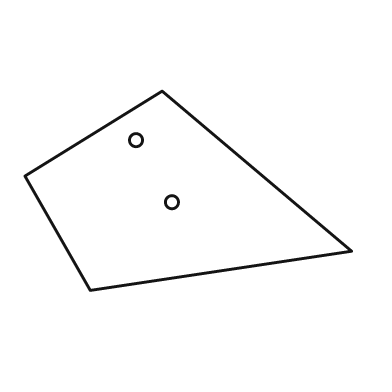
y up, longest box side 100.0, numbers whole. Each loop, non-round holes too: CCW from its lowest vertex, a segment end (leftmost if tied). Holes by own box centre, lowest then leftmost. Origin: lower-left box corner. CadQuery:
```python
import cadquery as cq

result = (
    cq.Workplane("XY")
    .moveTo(20.0, 0.0)
    .lineTo(100.0, 12.0)
    .lineTo(42.0, 61.0)
    .lineTo(0.0, 35.0)
    .close()
    .moveTo(45.0, 27.0)
    .circle(2.0)
    .moveTo(34.0, 46.0)
    .circle(2.0)
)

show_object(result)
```